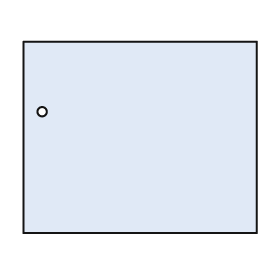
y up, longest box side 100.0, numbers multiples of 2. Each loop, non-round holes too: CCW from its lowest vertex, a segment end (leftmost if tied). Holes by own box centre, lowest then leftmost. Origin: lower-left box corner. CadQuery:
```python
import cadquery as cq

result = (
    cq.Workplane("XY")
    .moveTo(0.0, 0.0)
    .lineTo(100.0, 0.0)
    .lineTo(100.0, 82.0)
    .lineTo(0.0, 82.0)
    .close()
    .moveTo(8.0, 52.0)
    .circle(2.0)
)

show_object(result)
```